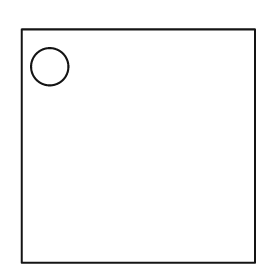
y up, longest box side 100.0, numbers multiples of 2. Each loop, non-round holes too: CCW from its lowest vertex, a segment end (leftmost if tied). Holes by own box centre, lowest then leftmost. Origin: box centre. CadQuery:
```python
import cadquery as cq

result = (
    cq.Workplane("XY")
    .moveTo(-50.0, -50.0)
    .lineTo(50.0, -50.0)
    .lineTo(50.0, 50.0)
    .lineTo(-50.0, 50.0)
    .close()
    .moveTo(-38.0, 34.0)
    .circle(8.0)
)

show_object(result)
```